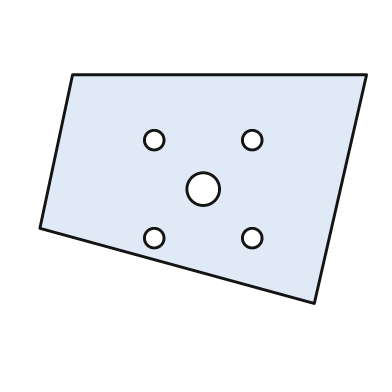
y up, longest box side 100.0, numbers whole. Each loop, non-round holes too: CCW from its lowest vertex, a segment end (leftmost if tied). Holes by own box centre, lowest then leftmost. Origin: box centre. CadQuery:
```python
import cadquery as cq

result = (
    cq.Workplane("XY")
    .moveTo(34.0, -35.0)
    .lineTo(50.0, 35.0)
    .lineTo(-40.0, 35.0)
    .lineTo(-50.0, -12.0)
    .close()
    .moveTo(-15.0, -15.0)
    .circle(3.0)
    .moveTo(15.0, -15.0)
    .circle(3.0)
    .moveTo(0.0, 0.0)
    .circle(5.0)
    .moveTo(-15.0, 15.0)
    .circle(3.0)
    .moveTo(15.0, 15.0)
    .circle(3.0)
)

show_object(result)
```